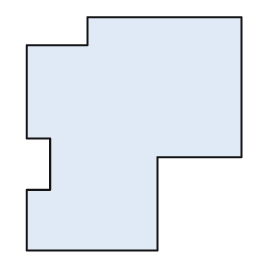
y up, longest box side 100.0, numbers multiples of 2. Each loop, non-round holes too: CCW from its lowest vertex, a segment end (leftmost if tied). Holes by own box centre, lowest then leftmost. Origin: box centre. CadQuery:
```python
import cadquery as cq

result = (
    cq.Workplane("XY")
    .moveTo(-46.0, -50.0)
    .lineTo(10.0, -50.0)
    .lineTo(10.0, -10.0)
    .lineTo(46.0, -10.0)
    .lineTo(46.0, 50.0)
    .lineTo(-20.0, 50.0)
    .lineTo(-20.0, 38.0)
    .lineTo(-46.0, 38.0)
    .lineTo(-46.0, -2.0)
    .lineTo(-36.0, -2.0)
    .lineTo(-36.0, -24.0)
    .lineTo(-46.0, -24.0)
    .close()
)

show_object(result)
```